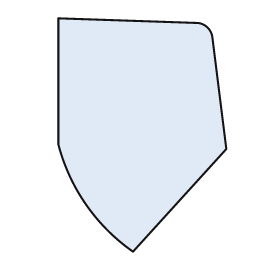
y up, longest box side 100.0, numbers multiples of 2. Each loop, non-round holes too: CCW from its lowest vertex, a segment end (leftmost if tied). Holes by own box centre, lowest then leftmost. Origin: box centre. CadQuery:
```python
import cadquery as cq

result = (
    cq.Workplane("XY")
    .moveTo(-4.0, -50.0)
    .lineTo(36.0, -6.0)
    .lineTo(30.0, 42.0)
    .threePointArc((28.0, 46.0), (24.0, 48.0))
    .lineTo(-36.0, 50.0)
    .lineTo(-36.0, -4.0)
    .threePointArc((-24.0, -30.0), (-4.0, -50.0))
    .close()
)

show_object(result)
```